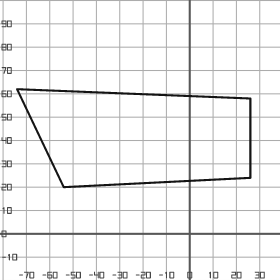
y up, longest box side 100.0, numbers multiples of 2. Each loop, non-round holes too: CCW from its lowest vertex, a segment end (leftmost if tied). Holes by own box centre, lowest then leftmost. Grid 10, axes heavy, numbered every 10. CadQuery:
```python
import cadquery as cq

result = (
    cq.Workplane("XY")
    .moveTo(-54.0, 20.0)
    .lineTo(26.0, 24.0)
    .lineTo(26.0, 58.0)
    .lineTo(-74.0, 62.0)
    .close()
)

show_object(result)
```